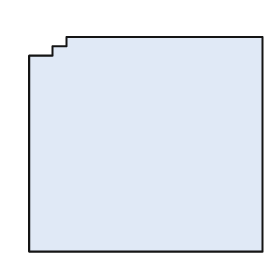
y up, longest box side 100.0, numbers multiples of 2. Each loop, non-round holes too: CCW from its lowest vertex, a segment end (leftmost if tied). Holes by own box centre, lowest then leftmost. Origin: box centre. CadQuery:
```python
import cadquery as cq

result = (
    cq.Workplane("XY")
    .moveTo(-50.0, -46.0)
    .lineTo(50.0, -46.0)
    .lineTo(50.0, 46.0)
    .lineTo(-34.0, 46.0)
    .lineTo(-34.0, 42.0)
    .lineTo(-40.0, 42.0)
    .lineTo(-40.0, 38.0)
    .lineTo(-50.0, 38.0)
    .close()
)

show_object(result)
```